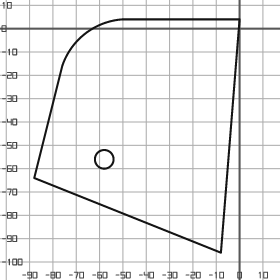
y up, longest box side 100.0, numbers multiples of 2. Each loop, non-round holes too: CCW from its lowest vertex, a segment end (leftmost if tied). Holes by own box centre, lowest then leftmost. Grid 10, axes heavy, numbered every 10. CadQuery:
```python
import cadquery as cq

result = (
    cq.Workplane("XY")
    .moveTo(-8.0, -96.0)
    .lineTo(0.0, 4.0)
    .lineTo(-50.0, 4.0)
    .threePointArc((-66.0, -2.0), (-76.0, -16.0))
    .lineTo(-88.0, -64.0)
    .close()
    .moveTo(-58.0, -56.0)
    .circle(4.0)
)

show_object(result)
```